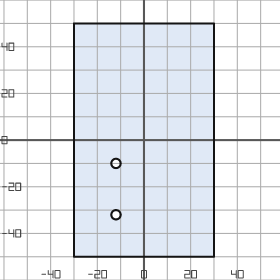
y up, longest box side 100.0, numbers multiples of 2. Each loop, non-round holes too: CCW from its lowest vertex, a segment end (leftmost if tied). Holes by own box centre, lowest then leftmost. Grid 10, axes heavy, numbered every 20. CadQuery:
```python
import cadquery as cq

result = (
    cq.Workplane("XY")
    .moveTo(-30.0, -50.0)
    .lineTo(30.0, -50.0)
    .lineTo(30.0, 50.0)
    .lineTo(-30.0, 50.0)
    .close()
    .moveTo(-12.0, -32.0)
    .circle(2.0)
    .moveTo(-12.0, -10.0)
    .circle(2.0)
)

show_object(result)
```